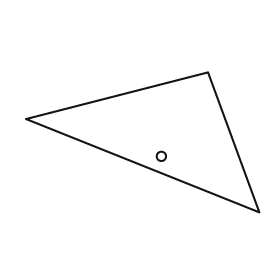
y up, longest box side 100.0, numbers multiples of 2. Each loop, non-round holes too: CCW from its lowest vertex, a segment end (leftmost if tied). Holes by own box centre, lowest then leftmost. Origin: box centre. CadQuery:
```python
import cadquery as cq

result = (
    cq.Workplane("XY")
    .moveTo(50.0, -30.0)
    .lineTo(28.0, 30.0)
    .lineTo(-50.0, 10.0)
    .close()
    .moveTo(8.0, -6.0)
    .circle(2.0)
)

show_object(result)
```